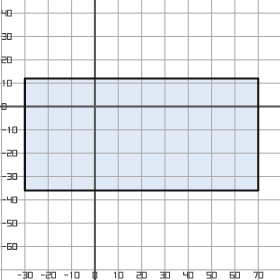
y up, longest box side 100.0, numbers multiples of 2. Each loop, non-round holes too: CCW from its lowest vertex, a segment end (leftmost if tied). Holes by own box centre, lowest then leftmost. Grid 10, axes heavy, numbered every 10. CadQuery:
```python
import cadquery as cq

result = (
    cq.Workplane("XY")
    .moveTo(-30.0, -36.0)
    .lineTo(70.0, -36.0)
    .lineTo(70.0, 12.0)
    .lineTo(-30.0, 12.0)
    .close()
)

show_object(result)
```